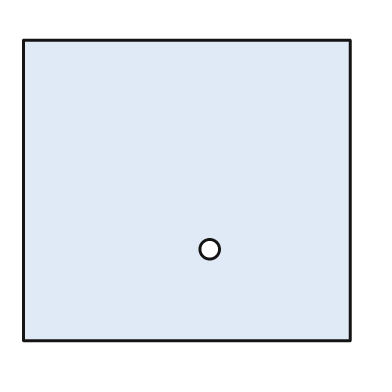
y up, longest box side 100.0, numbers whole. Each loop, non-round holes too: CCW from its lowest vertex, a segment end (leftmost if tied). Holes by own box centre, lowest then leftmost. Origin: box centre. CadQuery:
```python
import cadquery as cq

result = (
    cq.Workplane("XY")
    .moveTo(-50.0, -46.0)
    .lineTo(50.0, -46.0)
    .lineTo(50.0, 46.0)
    .lineTo(-50.0, 46.0)
    .close()
    .moveTo(7.0, -18.0)
    .circle(3.0)
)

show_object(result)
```